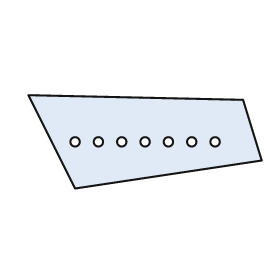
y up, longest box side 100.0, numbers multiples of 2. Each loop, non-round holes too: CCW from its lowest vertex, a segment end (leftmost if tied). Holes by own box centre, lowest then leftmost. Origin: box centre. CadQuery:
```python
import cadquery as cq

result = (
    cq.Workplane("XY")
    .moveTo(-30.0, -20.0)
    .lineTo(50.0, -8.0)
    .lineTo(42.0, 18.0)
    .lineTo(-50.0, 20.0)
    .close()
    .moveTo(-30.0, 0.0)
    .circle(2.0)
    .moveTo(-20.0, 0.0)
    .circle(2.0)
    .moveTo(-10.0, 0.0)
    .circle(2.0)
    .moveTo(0.0, 0.0)
    .circle(2.0)
    .moveTo(10.0, 0.0)
    .circle(2.0)
    .moveTo(20.0, 0.0)
    .circle(2.0)
    .moveTo(30.0, 0.0)
    .circle(2.0)
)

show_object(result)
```